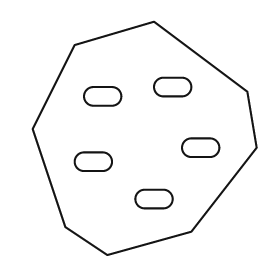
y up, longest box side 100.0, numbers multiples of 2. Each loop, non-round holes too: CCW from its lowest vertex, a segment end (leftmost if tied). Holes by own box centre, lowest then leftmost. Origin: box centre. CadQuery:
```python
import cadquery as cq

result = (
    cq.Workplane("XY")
    .moveTo(-16.0, -50.0)
    .lineTo(20.0, -40.0)
    .lineTo(48.0, -4.0)
    .lineTo(44.0, 20.0)
    .lineTo(4.0, 50.0)
    .lineTo(-30.0, 40.0)
    .lineTo(-48.0, 4.0)
    .lineTo(-34.0, -38.0)
    .close()
    .moveTo(0.0, -30.0)
    .lineTo(8.0, -30.0)
    .threePointArc((12.0, -26.0), (8.0, -22.0))
    .lineTo(0.0, -22.0)
    .threePointArc((-4.0, -26.0), (0.0, -30.0))
    .close()
    .moveTo(-26.0, -14.0)
    .lineTo(-18.0, -14.0)
    .threePointArc((-14.0, -10.0), (-18.0, -6.0))
    .lineTo(-26.0, -6.0)
    .threePointArc((-30.0, -10.0), (-26.0, -14.0))
    .close()
    .moveTo(20.0, -8.0)
    .lineTo(28.0, -8.0)
    .threePointArc((32.0, -4.0), (28.0, 0.0))
    .lineTo(20.0, 0.0)
    .threePointArc((16.0, -4.0), (20.0, -8.0))
    .close()
    .moveTo(-22.0, 14.0)
    .lineTo(-14.0, 14.0)
    .threePointArc((-10.0, 18.0), (-14.0, 22.0))
    .lineTo(-22.0, 22.0)
    .threePointArc((-26.0, 18.0), (-22.0, 14.0))
    .close()
    .moveTo(8.0, 18.0)
    .lineTo(16.0, 18.0)
    .threePointArc((20.0, 22.0), (16.0, 26.0))
    .lineTo(8.0, 26.0)
    .threePointArc((4.0, 22.0), (8.0, 18.0))
    .close()
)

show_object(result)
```